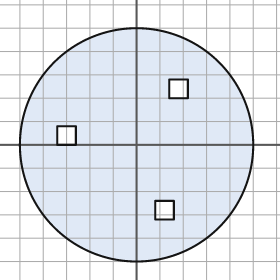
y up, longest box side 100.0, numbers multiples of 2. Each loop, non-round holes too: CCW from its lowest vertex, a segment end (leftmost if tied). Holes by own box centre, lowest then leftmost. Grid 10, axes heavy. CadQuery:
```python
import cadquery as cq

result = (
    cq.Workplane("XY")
    .moveTo(0.0, 0.0)
    .circle(50.0)
    .moveTo(8.0, -32.0)
    .lineTo(16.0, -32.0)
    .lineTo(16.0, -24.0)
    .lineTo(8.0, -24.0)
    .close()
    .moveTo(-34.0, 0.0)
    .lineTo(-26.0, 0.0)
    .lineTo(-26.0, 8.0)
    .lineTo(-34.0, 8.0)
    .close()
    .moveTo(14.0, 20.0)
    .lineTo(22.0, 20.0)
    .lineTo(22.0, 28.0)
    .lineTo(14.0, 28.0)
    .close()
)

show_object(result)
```